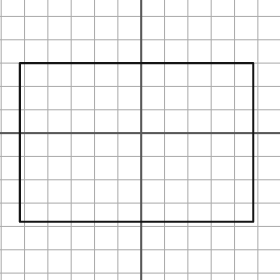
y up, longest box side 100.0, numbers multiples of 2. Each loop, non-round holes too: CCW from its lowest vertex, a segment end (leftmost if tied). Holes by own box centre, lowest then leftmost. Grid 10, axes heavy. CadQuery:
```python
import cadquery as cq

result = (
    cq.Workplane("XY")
    .moveTo(-52.0, -38.0)
    .lineTo(48.0, -38.0)
    .lineTo(48.0, 30.0)
    .lineTo(-52.0, 30.0)
    .close()
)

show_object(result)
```